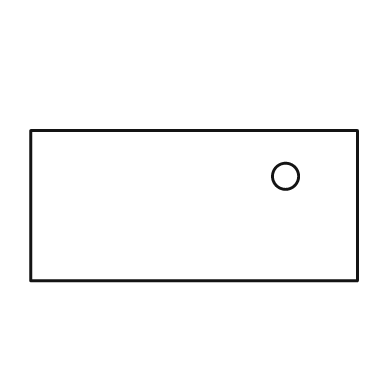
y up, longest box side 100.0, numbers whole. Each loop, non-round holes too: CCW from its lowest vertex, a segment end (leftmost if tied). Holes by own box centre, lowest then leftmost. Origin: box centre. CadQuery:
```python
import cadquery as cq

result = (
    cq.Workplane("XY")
    .moveTo(-50.0, -23.0)
    .lineTo(50.0, -23.0)
    .lineTo(50.0, 23.0)
    .lineTo(-50.0, 23.0)
    .close()
    .moveTo(28.0, 9.0)
    .circle(4.0)
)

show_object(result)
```